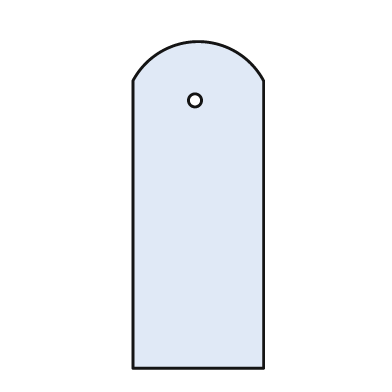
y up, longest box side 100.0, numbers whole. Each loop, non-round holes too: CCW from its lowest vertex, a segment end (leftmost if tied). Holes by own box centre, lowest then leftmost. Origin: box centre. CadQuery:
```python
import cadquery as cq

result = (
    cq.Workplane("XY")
    .moveTo(-20.0, -50.0)
    .lineTo(20.0, -50.0)
    .lineTo(20.0, 38.0)
    .threePointArc((0.0, 50.0), (-20.0, 38.0))
    .close()
    .moveTo(-1.0, 32.0)
    .circle(2.0)
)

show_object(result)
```